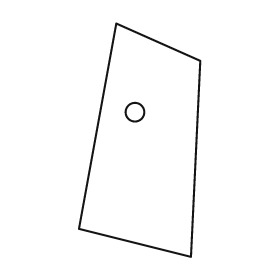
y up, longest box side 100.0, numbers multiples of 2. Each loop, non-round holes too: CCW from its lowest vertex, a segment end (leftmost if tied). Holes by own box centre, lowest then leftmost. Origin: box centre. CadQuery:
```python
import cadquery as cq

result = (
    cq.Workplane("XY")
    .moveTo(22.0, -50.0)
    .lineTo(26.0, 34.0)
    .lineTo(-10.0, 50.0)
    .lineTo(-26.0, -38.0)
    .close()
    .moveTo(-2.0, 12.0)
    .circle(4.0)
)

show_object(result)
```